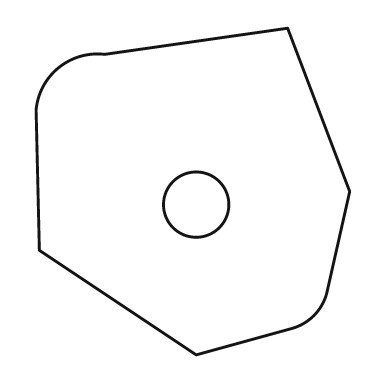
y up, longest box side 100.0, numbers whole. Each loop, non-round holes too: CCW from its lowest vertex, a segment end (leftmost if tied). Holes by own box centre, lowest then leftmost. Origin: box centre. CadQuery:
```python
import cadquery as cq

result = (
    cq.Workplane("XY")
    .moveTo(1.0, -50.0)
    .lineTo(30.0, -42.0)
    .threePointArc((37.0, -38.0), (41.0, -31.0))
    .lineTo(48.0, 0.0)
    .lineTo(29.0, 50.0)
    .lineTo(-27.0, 42.0)
    .threePointArc((-41.0, 38.0), (-48.0, 25.0))
    .lineTo(-47.0, -18.0)
    .close()
    .moveTo(1.0, -4.0)
    .circle(10.0)
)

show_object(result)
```